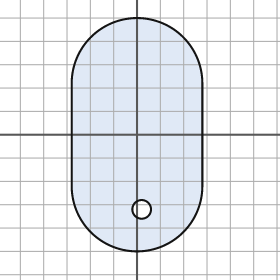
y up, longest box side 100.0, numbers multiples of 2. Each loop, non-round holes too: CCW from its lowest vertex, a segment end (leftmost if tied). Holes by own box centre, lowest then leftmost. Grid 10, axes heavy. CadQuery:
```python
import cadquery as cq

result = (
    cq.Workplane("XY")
    .moveTo(-28.0, -22.0)
    .threePointArc((0.0, -50.0), (28.0, -22.0))
    .lineTo(28.0, 22.0)
    .threePointArc((0.0, 50.0), (-28.0, 22.0))
    .close()
    .moveTo(2.0, -32.0)
    .circle(4.0)
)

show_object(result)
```